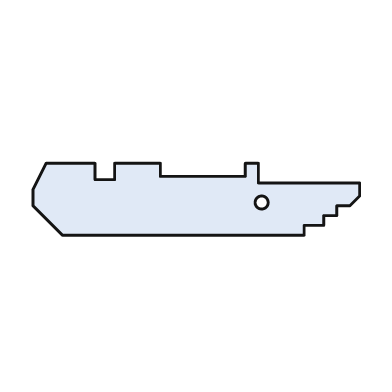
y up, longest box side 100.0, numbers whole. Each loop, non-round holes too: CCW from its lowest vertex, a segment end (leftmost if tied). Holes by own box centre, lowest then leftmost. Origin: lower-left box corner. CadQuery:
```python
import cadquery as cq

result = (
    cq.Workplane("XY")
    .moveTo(9.0, 0.0)
    .lineTo(83.0, 0.0)
    .lineTo(83.0, 3.0)
    .lineTo(89.0, 3.0)
    .lineTo(89.0, 6.0)
    .lineTo(93.0, 6.0)
    .lineTo(93.0, 9.0)
    .lineTo(97.0, 9.0)
    .lineTo(100.0, 12.0)
    .lineTo(100.0, 16.0)
    .lineTo(69.0, 16.0)
    .lineTo(69.0, 22.0)
    .lineTo(65.0, 22.0)
    .lineTo(65.0, 18.0)
    .lineTo(39.0, 18.0)
    .lineTo(39.0, 22.0)
    .lineTo(25.0, 22.0)
    .lineTo(25.0, 17.0)
    .lineTo(19.0, 17.0)
    .lineTo(19.0, 22.0)
    .lineTo(4.0, 22.0)
    .lineTo(0.0, 14.0)
    .lineTo(0.0, 9.0)
    .close()
    .moveTo(70.0, 10.0)
    .circle(2.0)
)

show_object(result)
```